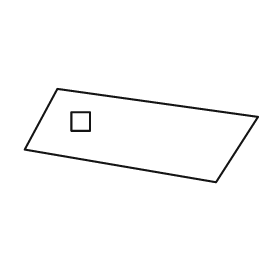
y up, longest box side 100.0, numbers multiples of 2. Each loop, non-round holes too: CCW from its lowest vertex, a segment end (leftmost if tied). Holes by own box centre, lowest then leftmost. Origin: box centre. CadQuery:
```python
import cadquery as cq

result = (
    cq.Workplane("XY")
    .moveTo(32.0, -20.0)
    .lineTo(50.0, 8.0)
    .lineTo(-36.0, 20.0)
    .lineTo(-50.0, -6.0)
    .close()
    .moveTo(-30.0, 2.0)
    .lineTo(-22.0, 2.0)
    .lineTo(-22.0, 10.0)
    .lineTo(-30.0, 10.0)
    .close()
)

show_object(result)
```